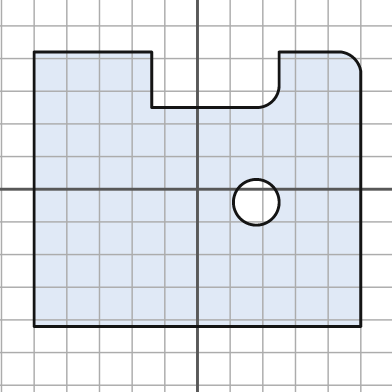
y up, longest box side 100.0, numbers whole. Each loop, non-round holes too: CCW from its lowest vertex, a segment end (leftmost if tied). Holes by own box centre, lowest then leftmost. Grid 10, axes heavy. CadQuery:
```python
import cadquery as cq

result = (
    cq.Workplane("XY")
    .moveTo(-50.0, -42.0)
    .lineTo(50.0, -42.0)
    .lineTo(50.0, 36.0)
    .threePointArc((48.0, 40.0), (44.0, 42.0))
    .lineTo(25.0, 42.0)
    .lineTo(25.0, 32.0)
    .threePointArc((23.0, 27.0), (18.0, 25.0))
    .lineTo(-14.0, 25.0)
    .lineTo(-14.0, 42.0)
    .lineTo(-50.0, 42.0)
    .close()
    .moveTo(18.0, -4.0)
    .circle(7.0)
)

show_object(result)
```